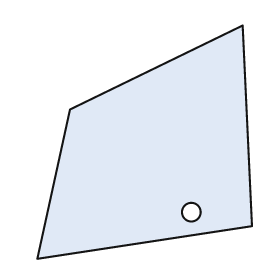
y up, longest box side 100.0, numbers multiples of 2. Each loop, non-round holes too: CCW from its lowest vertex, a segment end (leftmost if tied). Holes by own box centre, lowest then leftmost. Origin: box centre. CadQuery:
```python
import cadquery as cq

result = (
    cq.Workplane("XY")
    .moveTo(-46.0, -50.0)
    .lineTo(46.0, -36.0)
    .lineTo(42.0, 50.0)
    .lineTo(-32.0, 14.0)
    .close()
    .moveTo(20.0, -30.0)
    .circle(4.0)
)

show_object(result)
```